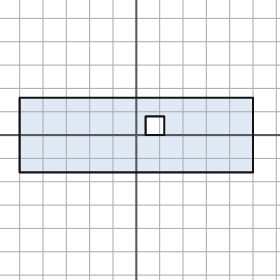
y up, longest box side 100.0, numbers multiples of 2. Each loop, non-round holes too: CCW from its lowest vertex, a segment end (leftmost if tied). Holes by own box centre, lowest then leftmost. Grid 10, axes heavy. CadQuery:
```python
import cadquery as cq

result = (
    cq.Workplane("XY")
    .moveTo(-50.0, -16.0)
    .lineTo(50.0, -16.0)
    .lineTo(50.0, 16.0)
    .lineTo(-50.0, 16.0)
    .close()
    .moveTo(4.0, 0.0)
    .lineTo(12.0, 0.0)
    .lineTo(12.0, 8.0)
    .lineTo(4.0, 8.0)
    .close()
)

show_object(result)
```